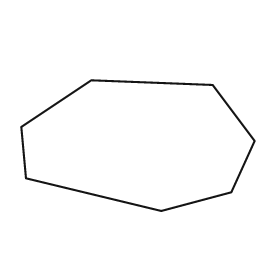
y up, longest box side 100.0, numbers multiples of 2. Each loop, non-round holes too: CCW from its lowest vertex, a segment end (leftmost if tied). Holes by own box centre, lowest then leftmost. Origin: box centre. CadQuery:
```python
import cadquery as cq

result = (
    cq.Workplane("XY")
    .moveTo(10.0, -28.0)
    .lineTo(40.0, -20.0)
    .lineTo(50.0, 2.0)
    .lineTo(32.0, 26.0)
    .lineTo(-20.0, 28.0)
    .lineTo(-50.0, 8.0)
    .lineTo(-48.0, -14.0)
    .close()
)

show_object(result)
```